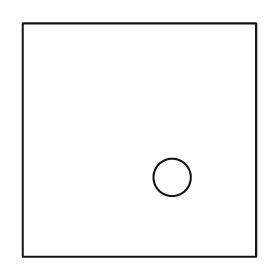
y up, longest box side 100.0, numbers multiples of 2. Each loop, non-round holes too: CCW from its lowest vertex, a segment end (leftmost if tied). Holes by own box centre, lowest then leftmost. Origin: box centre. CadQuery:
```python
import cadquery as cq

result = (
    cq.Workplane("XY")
    .moveTo(-50.0, -50.0)
    .lineTo(50.0, -50.0)
    .lineTo(50.0, 50.0)
    .lineTo(-50.0, 50.0)
    .close()
    .moveTo(14.0, -16.0)
    .circle(8.0)
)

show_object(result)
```